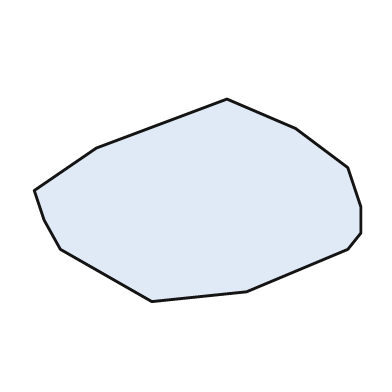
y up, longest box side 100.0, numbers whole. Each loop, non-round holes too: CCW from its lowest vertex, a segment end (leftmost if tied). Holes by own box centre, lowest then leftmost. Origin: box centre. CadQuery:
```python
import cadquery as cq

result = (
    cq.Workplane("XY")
    .moveTo(-14.0, -31.0)
    .lineTo(15.0, -28.0)
    .lineTo(46.0, -15.0)
    .lineTo(50.0, -10.0)
    .lineTo(50.0, -2.0)
    .lineTo(46.0, 10.0)
    .lineTo(30.0, 22.0)
    .lineTo(9.0, 31.0)
    .lineTo(-31.0, 16.0)
    .lineTo(-50.0, 3.0)
    .lineTo(-47.0, -6.0)
    .lineTo(-42.0, -15.0)
    .close()
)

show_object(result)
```